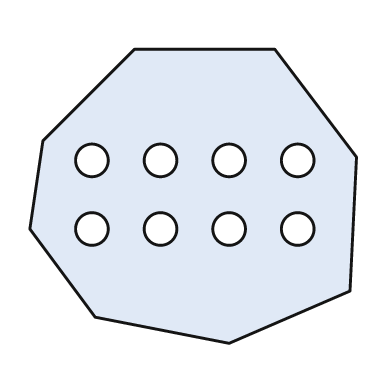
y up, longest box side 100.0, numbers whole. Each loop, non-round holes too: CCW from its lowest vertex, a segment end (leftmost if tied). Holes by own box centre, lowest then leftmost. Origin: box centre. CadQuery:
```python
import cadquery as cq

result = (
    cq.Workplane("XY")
    .moveTo(11.0, -45.0)
    .lineTo(48.0, -29.0)
    .lineTo(50.0, 12.0)
    .lineTo(25.0, 45.0)
    .lineTo(-18.0, 45.0)
    .lineTo(-46.0, 17.0)
    .lineTo(-50.0, -10.0)
    .lineTo(-30.0, -37.0)
    .close()
    .moveTo(-31.0, -10.0)
    .circle(5.0)
    .moveTo(-10.0, -10.0)
    .circle(5.0)
    .moveTo(11.0, -10.0)
    .circle(5.0)
    .moveTo(32.0, -10.0)
    .circle(5.0)
    .moveTo(-31.0, 11.0)
    .circle(5.0)
    .moveTo(-10.0, 11.0)
    .circle(5.0)
    .moveTo(11.0, 11.0)
    .circle(5.0)
    .moveTo(32.0, 11.0)
    .circle(5.0)
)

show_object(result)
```